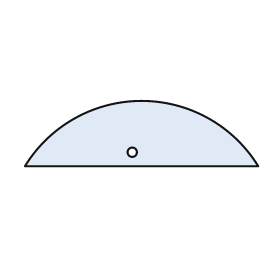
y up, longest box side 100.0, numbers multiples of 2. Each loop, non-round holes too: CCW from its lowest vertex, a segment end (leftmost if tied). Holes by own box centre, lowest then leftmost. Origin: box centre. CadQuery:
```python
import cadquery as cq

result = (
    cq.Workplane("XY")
    .moveTo(-50.0, -14.0)
    .lineTo(50.0, -14.0)
    .threePointArc((0.0, 14.0), (-50.0, -14.0))
    .close()
    .moveTo(-4.0, -8.0)
    .circle(2.0)
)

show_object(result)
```